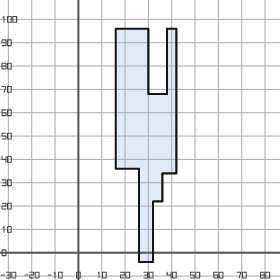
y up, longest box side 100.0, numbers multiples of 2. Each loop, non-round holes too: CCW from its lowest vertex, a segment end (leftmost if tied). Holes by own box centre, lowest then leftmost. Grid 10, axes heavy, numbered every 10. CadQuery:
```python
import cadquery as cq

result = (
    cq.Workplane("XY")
    .moveTo(26.0, -4.0)
    .lineTo(32.0, -4.0)
    .lineTo(32.0, 22.0)
    .lineTo(36.0, 22.0)
    .lineTo(36.0, 34.0)
    .lineTo(42.0, 34.0)
    .lineTo(42.0, 96.0)
    .lineTo(38.0, 96.0)
    .lineTo(38.0, 68.0)
    .lineTo(30.0, 68.0)
    .lineTo(30.0, 96.0)
    .lineTo(16.0, 96.0)
    .lineTo(16.0, 36.0)
    .lineTo(26.0, 36.0)
    .close()
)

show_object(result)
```